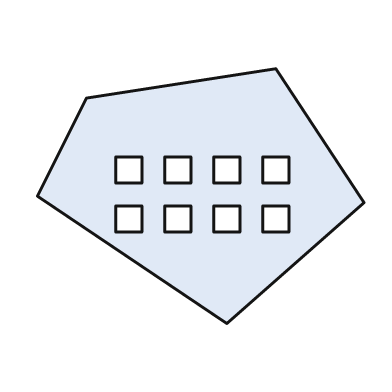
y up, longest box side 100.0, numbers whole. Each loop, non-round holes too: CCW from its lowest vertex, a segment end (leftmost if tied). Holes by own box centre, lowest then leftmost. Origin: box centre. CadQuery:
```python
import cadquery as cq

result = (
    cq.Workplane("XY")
    .moveTo(8.0, -39.0)
    .lineTo(50.0, -2.0)
    .lineTo(23.0, 39.0)
    .lineTo(-35.0, 30.0)
    .lineTo(-50.0, 0.0)
    .close()
    .moveTo(-26.0, -11.0)
    .lineTo(-18.0, -11.0)
    .lineTo(-18.0, -3.0)
    .lineTo(-26.0, -3.0)
    .close()
    .moveTo(-11.0, -11.0)
    .lineTo(-3.0, -11.0)
    .lineTo(-3.0, -3.0)
    .lineTo(-11.0, -3.0)
    .close()
    .moveTo(4.0, -11.0)
    .lineTo(12.0, -11.0)
    .lineTo(12.0, -3.0)
    .lineTo(4.0, -3.0)
    .close()
    .moveTo(19.0, -11.0)
    .lineTo(27.0, -11.0)
    .lineTo(27.0, -3.0)
    .lineTo(19.0, -3.0)
    .close()
    .moveTo(-26.0, 4.0)
    .lineTo(-18.0, 4.0)
    .lineTo(-18.0, 12.0)
    .lineTo(-26.0, 12.0)
    .close()
    .moveTo(-11.0, 4.0)
    .lineTo(-3.0, 4.0)
    .lineTo(-3.0, 12.0)
    .lineTo(-11.0, 12.0)
    .close()
    .moveTo(4.0, 4.0)
    .lineTo(12.0, 4.0)
    .lineTo(12.0, 12.0)
    .lineTo(4.0, 12.0)
    .close()
    .moveTo(19.0, 4.0)
    .lineTo(27.0, 4.0)
    .lineTo(27.0, 12.0)
    .lineTo(19.0, 12.0)
    .close()
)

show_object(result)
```